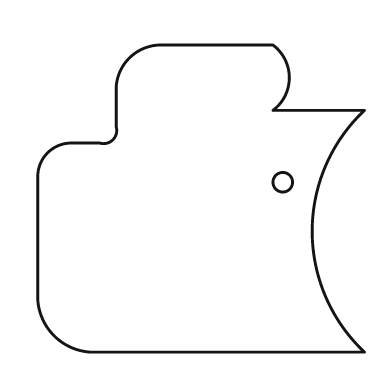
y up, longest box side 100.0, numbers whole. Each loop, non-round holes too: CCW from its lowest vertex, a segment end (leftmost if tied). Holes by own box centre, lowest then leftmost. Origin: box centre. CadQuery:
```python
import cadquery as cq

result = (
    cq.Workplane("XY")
    .moveTo(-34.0, -47.0)
    .lineTo(50.0, -47.0)
    .threePointArc((34.0, -10.0), (50.0, 27.0))
    .lineTo(22.0, 27.0)
    .threePointArc((27.0, 37.0), (22.0, 47.0))
    .lineTo(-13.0, 47.0)
    .threePointArc((-22.0, 43.0), (-26.0, 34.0))
    .lineTo(-26.0, 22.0)
    .threePointArc((-27.0, 18.0), (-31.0, 17.0))
    .lineTo(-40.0, 17.0)
    .threePointArc((-47.0, 14.0), (-50.0, 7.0))
    .lineTo(-50.0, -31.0)
    .threePointArc((-45.0, -42.0), (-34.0, -47.0))
    .close()
    .moveTo(25.0, 5.0)
    .circle(3.0)
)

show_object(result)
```